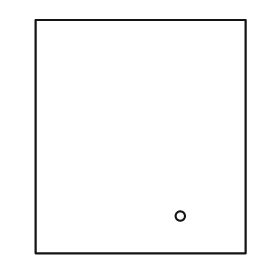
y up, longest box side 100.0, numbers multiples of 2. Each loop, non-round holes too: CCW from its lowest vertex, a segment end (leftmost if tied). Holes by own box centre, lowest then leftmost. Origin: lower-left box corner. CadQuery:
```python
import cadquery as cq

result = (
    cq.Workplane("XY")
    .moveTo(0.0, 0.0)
    .lineTo(90.0, 0.0)
    .lineTo(90.0, 100.0)
    .lineTo(0.0, 100.0)
    .close()
    .moveTo(62.0, 16.0)
    .circle(2.0)
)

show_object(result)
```